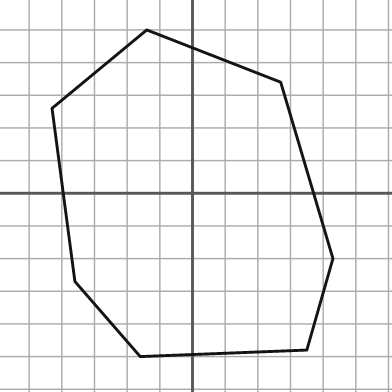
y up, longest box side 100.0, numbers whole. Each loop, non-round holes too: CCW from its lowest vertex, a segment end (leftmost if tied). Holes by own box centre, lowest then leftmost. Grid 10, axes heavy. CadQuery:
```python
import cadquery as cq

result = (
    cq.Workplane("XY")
    .moveTo(-16.0, -50.0)
    .lineTo(35.0, -48.0)
    .lineTo(43.0, -20.0)
    .lineTo(27.0, 34.0)
    .lineTo(-14.0, 50.0)
    .lineTo(-43.0, 26.0)
    .lineTo(-36.0, -27.0)
    .close()
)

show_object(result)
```